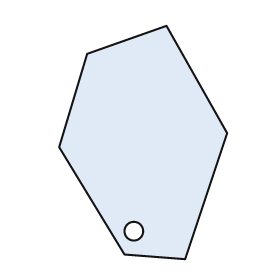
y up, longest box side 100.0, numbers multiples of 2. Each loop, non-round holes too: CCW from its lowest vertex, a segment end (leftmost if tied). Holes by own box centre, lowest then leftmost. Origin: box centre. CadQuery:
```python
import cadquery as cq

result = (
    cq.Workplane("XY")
    .moveTo(18.0, -50.0)
    .lineTo(36.0, 4.0)
    .lineTo(10.0, 50.0)
    .lineTo(-24.0, 38.0)
    .lineTo(-36.0, -2.0)
    .lineTo(-8.0, -48.0)
    .close()
    .moveTo(-4.0, -38.0)
    .circle(4.0)
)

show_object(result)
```